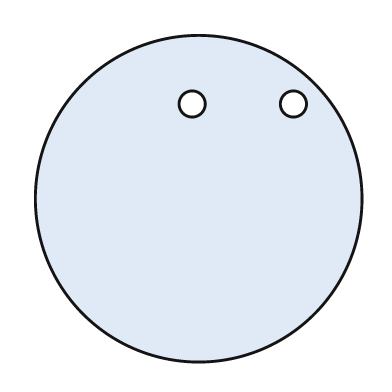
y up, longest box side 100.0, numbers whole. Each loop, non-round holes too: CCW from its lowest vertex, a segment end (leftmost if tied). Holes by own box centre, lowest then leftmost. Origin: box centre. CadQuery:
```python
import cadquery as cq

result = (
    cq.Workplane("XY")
    .moveTo(0.0, 0.0)
    .circle(50.0)
    .moveTo(-2.0, 29.0)
    .circle(4.0)
    .moveTo(29.0, 29.0)
    .circle(4.0)
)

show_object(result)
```